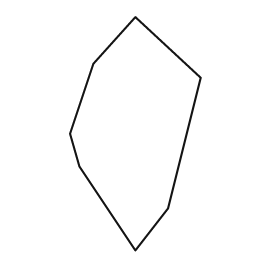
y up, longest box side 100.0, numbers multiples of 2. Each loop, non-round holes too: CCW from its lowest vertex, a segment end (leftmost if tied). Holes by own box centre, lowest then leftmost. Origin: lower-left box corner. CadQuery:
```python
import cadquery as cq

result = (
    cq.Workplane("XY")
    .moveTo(28.0, 0.0)
    .lineTo(42.0, 18.0)
    .lineTo(56.0, 74.0)
    .lineTo(28.0, 100.0)
    .lineTo(10.0, 80.0)
    .lineTo(0.0, 50.0)
    .lineTo(4.0, 36.0)
    .close()
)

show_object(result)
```